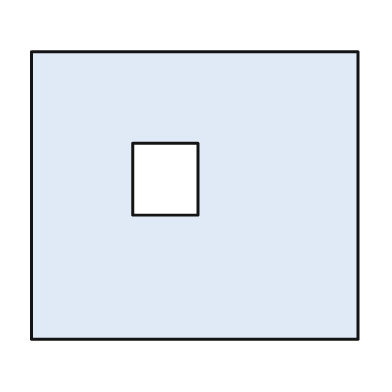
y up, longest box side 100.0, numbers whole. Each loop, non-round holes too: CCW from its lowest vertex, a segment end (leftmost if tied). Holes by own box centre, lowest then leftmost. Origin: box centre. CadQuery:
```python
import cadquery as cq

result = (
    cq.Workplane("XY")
    .moveTo(-50.0, -44.0)
    .lineTo(50.0, -44.0)
    .lineTo(50.0, 44.0)
    .lineTo(-50.0, 44.0)
    .close()
    .moveTo(-19.0, -6.0)
    .lineTo(1.0, -6.0)
    .lineTo(1.0, 16.0)
    .lineTo(-19.0, 16.0)
    .close()
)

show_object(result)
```